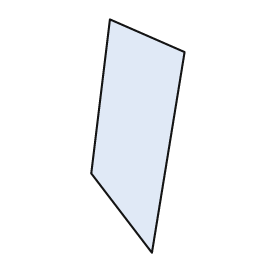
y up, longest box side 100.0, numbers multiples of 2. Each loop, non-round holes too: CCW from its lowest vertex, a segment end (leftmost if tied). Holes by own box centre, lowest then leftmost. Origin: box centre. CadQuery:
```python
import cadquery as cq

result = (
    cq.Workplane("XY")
    .moveTo(6.0, -50.0)
    .lineTo(20.0, 36.0)
    .lineTo(-12.0, 50.0)
    .lineTo(-20.0, -16.0)
    .close()
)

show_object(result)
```